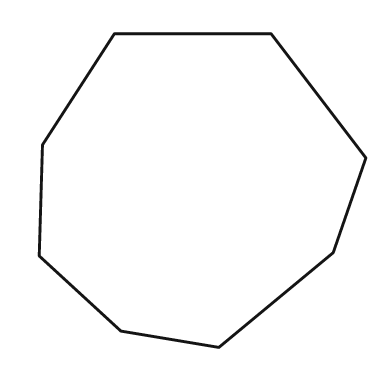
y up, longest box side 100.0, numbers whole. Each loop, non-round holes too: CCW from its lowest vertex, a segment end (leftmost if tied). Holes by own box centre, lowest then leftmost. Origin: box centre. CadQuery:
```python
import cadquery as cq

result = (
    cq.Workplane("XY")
    .moveTo(5.0, -48.0)
    .lineTo(40.0, -19.0)
    .lineTo(50.0, 10.0)
    .lineTo(21.0, 48.0)
    .lineTo(-27.0, 48.0)
    .lineTo(-49.0, 14.0)
    .lineTo(-50.0, -20.0)
    .lineTo(-25.0, -43.0)
    .close()
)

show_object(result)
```